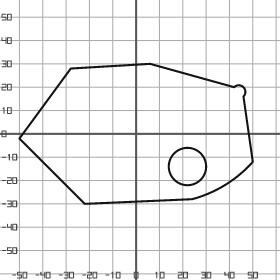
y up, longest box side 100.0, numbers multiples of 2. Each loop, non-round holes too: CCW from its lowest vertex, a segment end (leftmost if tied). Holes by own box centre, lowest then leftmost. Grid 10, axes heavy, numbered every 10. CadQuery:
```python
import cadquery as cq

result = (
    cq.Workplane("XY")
    .moveTo(-22.0, -30.0)
    .lineTo(24.0, -28.0)
    .threePointArc((38.0, -22.0), (50.0, -12.0))
    .lineTo(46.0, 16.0)
    .threePointArc((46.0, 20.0), (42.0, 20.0))
    .lineTo(6.0, 30.0)
    .lineTo(-28.0, 28.0)
    .lineTo(-50.0, -2.0)
    .close()
    .moveTo(22.0, -14.0)
    .circle(8.0)
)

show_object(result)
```